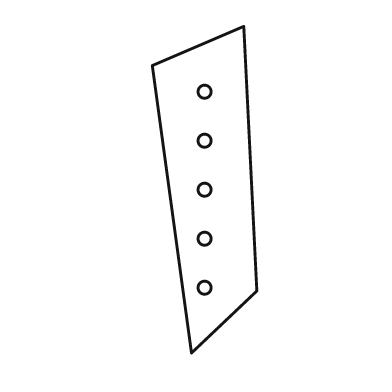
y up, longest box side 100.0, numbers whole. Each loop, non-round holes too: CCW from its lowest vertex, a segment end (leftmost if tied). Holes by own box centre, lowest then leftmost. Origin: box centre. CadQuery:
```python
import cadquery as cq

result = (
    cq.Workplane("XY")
    .moveTo(-4.0, -50.0)
    .lineTo(16.0, -31.0)
    .lineTo(12.0, 50.0)
    .lineTo(-16.0, 38.0)
    .close()
    .moveTo(0.0, -30.0)
    .circle(2.0)
    .moveTo(0.0, -15.0)
    .circle(2.0)
    .moveTo(0.0, 0.0)
    .circle(2.0)
    .moveTo(0.0, 15.0)
    .circle(2.0)
    .moveTo(0.0, 30.0)
    .circle(2.0)
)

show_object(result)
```